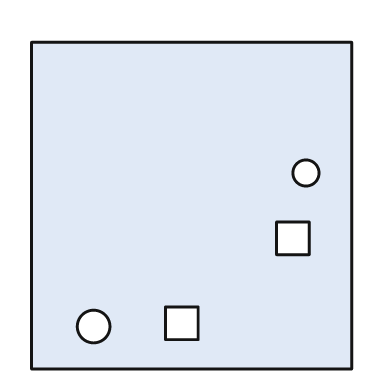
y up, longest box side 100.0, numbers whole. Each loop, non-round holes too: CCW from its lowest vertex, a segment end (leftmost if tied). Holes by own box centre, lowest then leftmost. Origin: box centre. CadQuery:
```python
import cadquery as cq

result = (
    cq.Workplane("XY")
    .moveTo(-49.0, -50.0)
    .lineTo(49.0, -50.0)
    .lineTo(49.0, 50.0)
    .lineTo(-49.0, 50.0)
    .close()
    .moveTo(-30.0, -37.0)
    .circle(5.0)
    .moveTo(-8.0, -41.0)
    .lineTo(2.0, -41.0)
    .lineTo(2.0, -31.0)
    .lineTo(-8.0, -31.0)
    .close()
    .moveTo(26.0, -15.0)
    .lineTo(36.0, -15.0)
    .lineTo(36.0, -5.0)
    .lineTo(26.0, -5.0)
    .close()
    .moveTo(35.0, 10.0)
    .circle(4.0)
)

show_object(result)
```